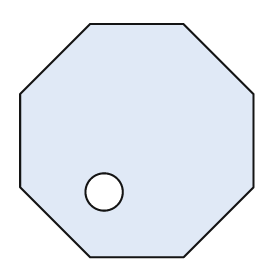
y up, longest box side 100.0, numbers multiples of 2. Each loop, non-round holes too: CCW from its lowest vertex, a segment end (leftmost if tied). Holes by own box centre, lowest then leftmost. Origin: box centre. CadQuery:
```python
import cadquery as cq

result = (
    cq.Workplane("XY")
    .moveTo(-20.0, -50.0)
    .lineTo(20.0, -50.0)
    .lineTo(50.0, -20.0)
    .lineTo(50.0, 20.0)
    .lineTo(20.0, 50.0)
    .lineTo(-20.0, 50.0)
    .lineTo(-50.0, 20.0)
    .lineTo(-50.0, -20.0)
    .close()
    .moveTo(-14.0, -22.0)
    .circle(8.0)
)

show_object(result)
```